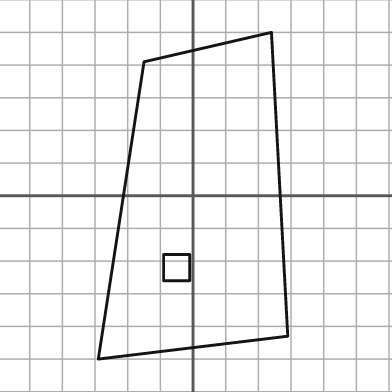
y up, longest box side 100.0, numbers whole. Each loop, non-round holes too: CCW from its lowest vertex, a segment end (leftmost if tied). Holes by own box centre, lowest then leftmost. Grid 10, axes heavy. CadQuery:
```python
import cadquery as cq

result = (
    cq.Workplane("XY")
    .moveTo(-29.0, -50.0)
    .lineTo(29.0, -43.0)
    .lineTo(24.0, 50.0)
    .lineTo(-15.0, 41.0)
    .close()
    .moveTo(-9.0, -26.0)
    .lineTo(-1.0, -26.0)
    .lineTo(-1.0, -18.0)
    .lineTo(-9.0, -18.0)
    .close()
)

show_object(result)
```